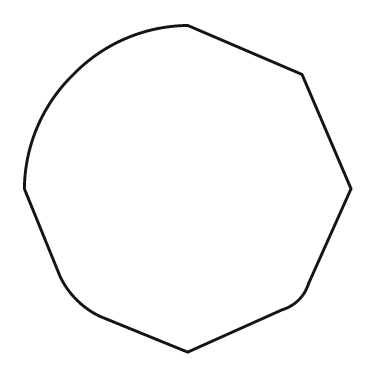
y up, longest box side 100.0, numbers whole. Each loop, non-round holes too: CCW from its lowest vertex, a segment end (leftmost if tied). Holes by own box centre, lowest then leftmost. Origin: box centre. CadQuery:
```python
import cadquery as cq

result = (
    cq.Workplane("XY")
    .moveTo(0.0, -50.0)
    .lineTo(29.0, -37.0)
    .threePointArc((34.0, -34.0), (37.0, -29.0))
    .lineTo(50.0, 0.0)
    .lineTo(35.0, 35.0)
    .lineTo(0.0, 50.0)
    .threePointArc((-19.0, 46.0), (-35.0, 35.0))
    .threePointArc((-46.0, 19.0), (-50.0, 0.0))
    .lineTo(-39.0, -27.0)
    .threePointArc((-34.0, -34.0), (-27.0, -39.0))
    .close()
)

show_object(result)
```